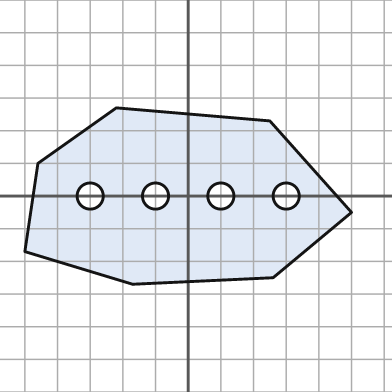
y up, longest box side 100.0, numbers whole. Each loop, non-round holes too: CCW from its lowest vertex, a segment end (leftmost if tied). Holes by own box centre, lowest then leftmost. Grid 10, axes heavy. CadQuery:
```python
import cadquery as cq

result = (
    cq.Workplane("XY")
    .moveTo(-17.0, -27.0)
    .lineTo(26.0, -25.0)
    .lineTo(50.0, -5.0)
    .lineTo(25.0, 23.0)
    .lineTo(-22.0, 27.0)
    .lineTo(-46.0, 10.0)
    .lineTo(-50.0, -17.0)
    .close()
    .moveTo(-30.0, 0.0)
    .circle(4.0)
    .moveTo(-10.0, 0.0)
    .circle(4.0)
    .moveTo(10.0, 0.0)
    .circle(4.0)
    .moveTo(30.0, 0.0)
    .circle(4.0)
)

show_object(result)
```